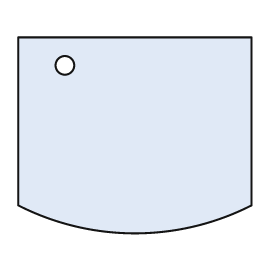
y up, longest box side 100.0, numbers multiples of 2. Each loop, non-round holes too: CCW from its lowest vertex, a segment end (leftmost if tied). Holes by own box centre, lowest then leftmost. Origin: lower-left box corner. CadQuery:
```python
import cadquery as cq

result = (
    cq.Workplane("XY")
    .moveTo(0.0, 12.0)
    .threePointArc((50.0, 0.0), (100.0, 12.0))
    .lineTo(100.0, 84.0)
    .lineTo(0.0, 84.0)
    .close()
    .moveTo(20.0, 72.0)
    .circle(4.0)
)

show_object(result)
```